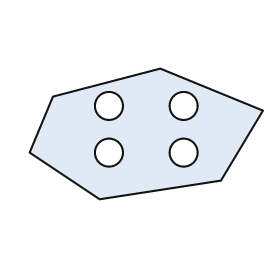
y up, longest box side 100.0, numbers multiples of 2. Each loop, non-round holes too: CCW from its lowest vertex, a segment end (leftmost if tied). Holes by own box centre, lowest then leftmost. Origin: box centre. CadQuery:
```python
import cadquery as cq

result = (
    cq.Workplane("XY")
    .moveTo(-20.0, -28.0)
    .lineTo(32.0, -20.0)
    .lineTo(50.0, 10.0)
    .lineTo(6.0, 28.0)
    .lineTo(-40.0, 16.0)
    .lineTo(-50.0, -8.0)
    .close()
    .moveTo(-16.0, -8.0)
    .circle(6.0)
    .moveTo(16.0, -8.0)
    .circle(6.0)
    .moveTo(-16.0, 12.0)
    .circle(6.0)
    .moveTo(16.0, 12.0)
    .circle(6.0)
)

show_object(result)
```